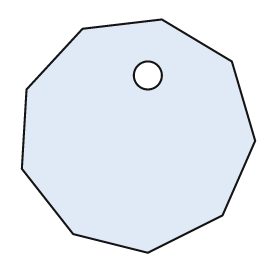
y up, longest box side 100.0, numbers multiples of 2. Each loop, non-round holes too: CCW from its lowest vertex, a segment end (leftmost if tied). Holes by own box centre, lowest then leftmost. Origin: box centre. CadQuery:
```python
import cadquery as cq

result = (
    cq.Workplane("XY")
    .moveTo(4.0, -50.0)
    .lineTo(36.0, -34.0)
    .lineTo(50.0, -2.0)
    .lineTo(40.0, 32.0)
    .lineTo(10.0, 50.0)
    .lineTo(-24.0, 46.0)
    .lineTo(-48.0, 20.0)
    .lineTo(-50.0, -14.0)
    .lineTo(-28.0, -42.0)
    .close()
    .moveTo(4.0, 26.0)
    .circle(6.0)
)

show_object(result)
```